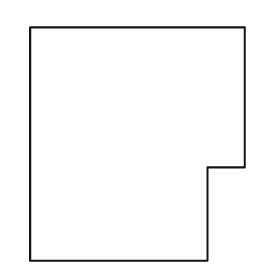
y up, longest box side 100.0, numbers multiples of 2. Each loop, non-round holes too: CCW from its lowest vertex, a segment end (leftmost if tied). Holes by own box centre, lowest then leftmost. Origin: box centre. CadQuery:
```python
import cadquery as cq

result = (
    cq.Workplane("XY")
    .moveTo(-46.0, -50.0)
    .lineTo(30.0, -50.0)
    .lineTo(30.0, -10.0)
    .lineTo(46.0, -10.0)
    .lineTo(46.0, 50.0)
    .lineTo(-46.0, 50.0)
    .close()
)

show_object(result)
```